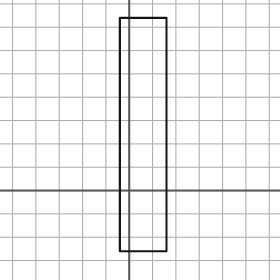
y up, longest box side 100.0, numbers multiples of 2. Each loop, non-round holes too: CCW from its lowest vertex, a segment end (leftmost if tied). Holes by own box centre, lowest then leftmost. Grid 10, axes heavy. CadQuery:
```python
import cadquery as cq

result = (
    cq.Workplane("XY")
    .moveTo(-4.0, -26.0)
    .lineTo(16.0, -26.0)
    .lineTo(16.0, 74.0)
    .lineTo(-4.0, 74.0)
    .close()
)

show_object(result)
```